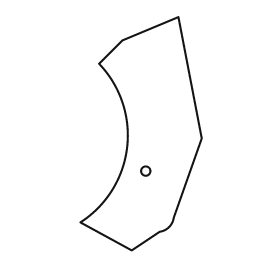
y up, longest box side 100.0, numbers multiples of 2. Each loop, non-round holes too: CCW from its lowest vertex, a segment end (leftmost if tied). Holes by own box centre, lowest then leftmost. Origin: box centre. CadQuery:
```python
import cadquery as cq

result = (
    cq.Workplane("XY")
    .moveTo(-4.0, -50.0)
    .lineTo(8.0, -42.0)
    .threePointArc((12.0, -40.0), (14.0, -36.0))
    .lineTo(26.0, -2.0)
    .lineTo(16.0, 50.0)
    .lineTo(-8.0, 40.0)
    .lineTo(-18.0, 30.0)
    .threePointArc((-6.0, -6.0), (-26.0, -38.0))
    .close()
    .moveTo(2.0, -16.0)
    .circle(2.0)
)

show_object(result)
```